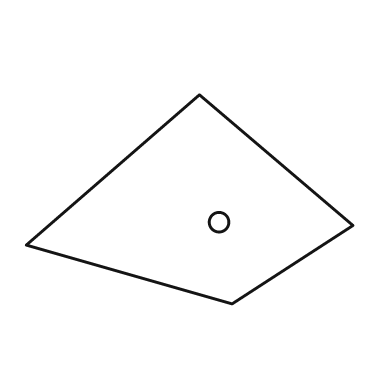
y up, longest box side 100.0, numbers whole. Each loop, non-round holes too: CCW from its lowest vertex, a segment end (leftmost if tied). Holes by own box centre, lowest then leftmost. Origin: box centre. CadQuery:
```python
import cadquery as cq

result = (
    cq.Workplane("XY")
    .moveTo(13.0, -32.0)
    .lineTo(50.0, -8.0)
    .lineTo(3.0, 32.0)
    .lineTo(-50.0, -14.0)
    .close()
    .moveTo(9.0, -7.0)
    .circle(3.0)
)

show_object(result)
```